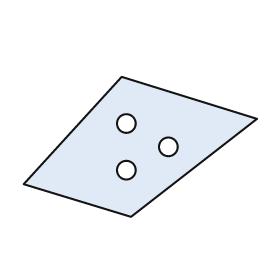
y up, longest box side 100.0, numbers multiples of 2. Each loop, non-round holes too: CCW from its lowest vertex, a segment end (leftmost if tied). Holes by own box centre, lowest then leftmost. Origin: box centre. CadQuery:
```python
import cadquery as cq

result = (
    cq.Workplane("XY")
    .moveTo(-4.0, -30.0)
    .lineTo(50.0, 12.0)
    .lineTo(-8.0, 30.0)
    .lineTo(-50.0, -16.0)
    .close()
    .moveTo(-6.0, -10.0)
    .circle(4.0)
    .moveTo(12.0, 0.0)
    .circle(4.0)
    .moveTo(-6.0, 10.0)
    .circle(4.0)
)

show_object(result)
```